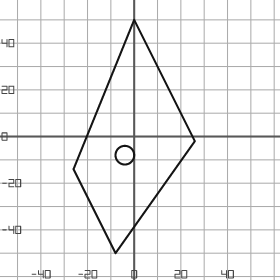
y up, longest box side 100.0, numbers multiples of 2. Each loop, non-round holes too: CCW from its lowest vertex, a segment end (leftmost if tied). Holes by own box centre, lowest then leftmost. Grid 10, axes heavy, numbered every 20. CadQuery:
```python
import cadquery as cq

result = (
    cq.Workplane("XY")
    .moveTo(-8.0, -50.0)
    .lineTo(26.0, -2.0)
    .lineTo(0.0, 50.0)
    .lineTo(-26.0, -14.0)
    .close()
    .moveTo(-4.0, -8.0)
    .circle(4.0)
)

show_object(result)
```